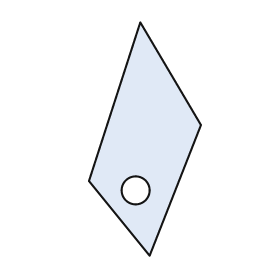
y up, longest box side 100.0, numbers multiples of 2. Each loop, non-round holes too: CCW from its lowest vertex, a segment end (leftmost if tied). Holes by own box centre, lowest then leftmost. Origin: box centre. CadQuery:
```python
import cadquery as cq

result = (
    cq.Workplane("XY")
    .moveTo(2.0, -50.0)
    .lineTo(24.0, 6.0)
    .lineTo(-2.0, 50.0)
    .lineTo(-24.0, -18.0)
    .close()
    .moveTo(-4.0, -22.0)
    .circle(6.0)
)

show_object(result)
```